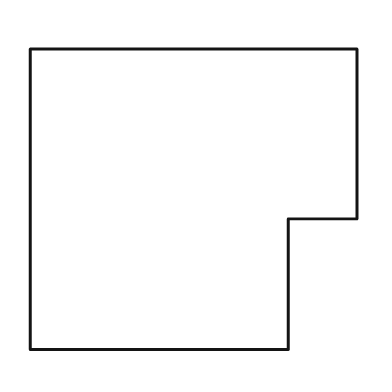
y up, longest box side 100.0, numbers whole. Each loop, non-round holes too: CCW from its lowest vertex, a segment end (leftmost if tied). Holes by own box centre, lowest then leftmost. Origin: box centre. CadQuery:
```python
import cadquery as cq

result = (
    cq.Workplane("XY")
    .moveTo(-50.0, -46.0)
    .lineTo(29.0, -46.0)
    .lineTo(29.0, -6.0)
    .lineTo(50.0, -6.0)
    .lineTo(50.0, 46.0)
    .lineTo(-50.0, 46.0)
    .close()
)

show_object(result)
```